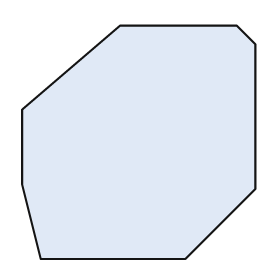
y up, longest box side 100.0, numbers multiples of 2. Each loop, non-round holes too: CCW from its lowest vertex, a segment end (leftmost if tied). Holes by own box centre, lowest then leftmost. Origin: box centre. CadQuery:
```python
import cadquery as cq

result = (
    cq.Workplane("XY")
    .moveTo(-42.0, -50.0)
    .lineTo(20.0, -50.0)
    .lineTo(50.0, -20.0)
    .lineTo(50.0, 42.0)
    .lineTo(42.0, 50.0)
    .lineTo(-8.0, 50.0)
    .lineTo(-50.0, 14.0)
    .lineTo(-50.0, -18.0)
    .close()
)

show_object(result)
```